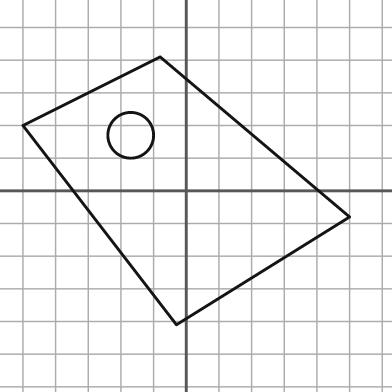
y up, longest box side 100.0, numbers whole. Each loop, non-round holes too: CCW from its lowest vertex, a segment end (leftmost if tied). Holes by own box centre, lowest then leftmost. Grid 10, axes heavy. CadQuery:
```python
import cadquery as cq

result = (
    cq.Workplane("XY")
    .moveTo(-3.0, -41.0)
    .lineTo(50.0, -8.0)
    .lineTo(-8.0, 41.0)
    .lineTo(-50.0, 20.0)
    .close()
    .moveTo(-17.0, 17.0)
    .circle(7.0)
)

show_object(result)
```